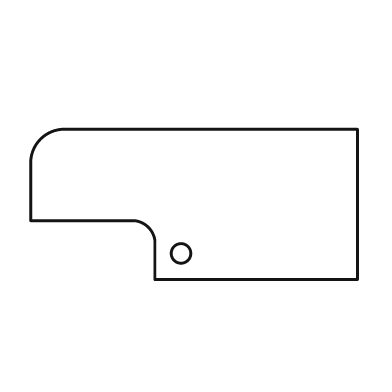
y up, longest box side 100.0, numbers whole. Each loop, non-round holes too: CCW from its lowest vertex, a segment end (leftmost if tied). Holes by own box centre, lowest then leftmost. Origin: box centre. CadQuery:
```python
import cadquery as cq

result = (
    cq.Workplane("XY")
    .moveTo(-12.0, -23.0)
    .lineTo(50.0, -23.0)
    .lineTo(50.0, 23.0)
    .lineTo(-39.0, 23.0)
    .threePointArc((-47.0, 20.0), (-50.0, 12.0))
    .lineTo(-50.0, -5.0)
    .lineTo(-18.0, -5.0)
    .threePointArc((-14.0, -7.0), (-12.0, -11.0))
    .close()
    .moveTo(-4.0, -15.0)
    .circle(3.0)
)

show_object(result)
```